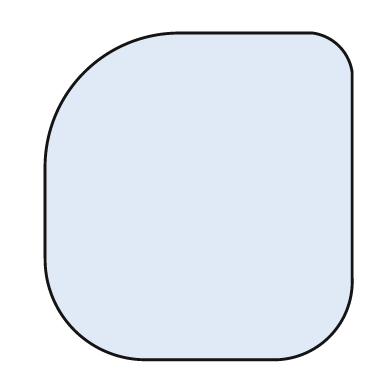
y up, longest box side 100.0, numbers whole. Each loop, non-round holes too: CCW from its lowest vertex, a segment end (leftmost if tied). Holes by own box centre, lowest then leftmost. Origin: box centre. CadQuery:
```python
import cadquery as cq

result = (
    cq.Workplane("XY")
    .moveTo(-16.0, -50.0)
    .lineTo(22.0, -50.0)
    .threePointArc((40.0, -43.0), (47.0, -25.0))
    .lineTo(47.0, 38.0)
    .threePointArc((43.0, 46.0), (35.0, 50.0))
    .lineTo(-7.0, 50.0)
    .threePointArc((-35.0, 38.0), (-47.0, 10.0))
    .lineTo(-47.0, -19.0)
    .threePointArc((-38.0, -41.0), (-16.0, -50.0))
    .close()
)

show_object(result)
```